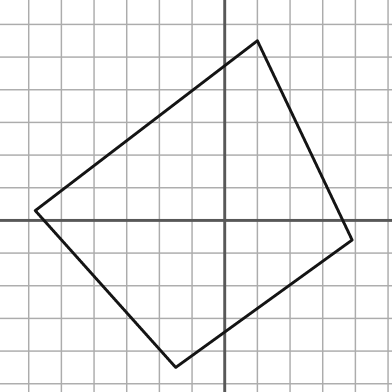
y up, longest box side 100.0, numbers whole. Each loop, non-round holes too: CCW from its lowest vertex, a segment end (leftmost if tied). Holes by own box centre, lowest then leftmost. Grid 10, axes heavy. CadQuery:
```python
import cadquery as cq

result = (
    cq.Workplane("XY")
    .moveTo(-15.0, -45.0)
    .lineTo(39.0, -6.0)
    .lineTo(10.0, 55.0)
    .lineTo(-58.0, 3.0)
    .close()
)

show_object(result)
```